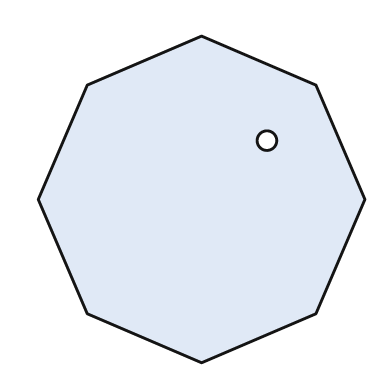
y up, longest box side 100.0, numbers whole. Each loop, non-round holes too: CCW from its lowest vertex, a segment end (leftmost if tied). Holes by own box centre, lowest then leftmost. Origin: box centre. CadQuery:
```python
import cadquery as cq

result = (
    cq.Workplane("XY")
    .moveTo(0.0, -50.0)
    .lineTo(35.0, -35.0)
    .lineTo(50.0, 0.0)
    .lineTo(35.0, 35.0)
    .lineTo(0.0, 50.0)
    .lineTo(-35.0, 35.0)
    .lineTo(-50.0, 0.0)
    .lineTo(-35.0, -35.0)
    .close()
    .moveTo(20.0, 18.0)
    .circle(3.0)
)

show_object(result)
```